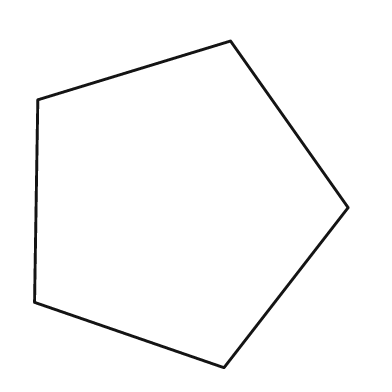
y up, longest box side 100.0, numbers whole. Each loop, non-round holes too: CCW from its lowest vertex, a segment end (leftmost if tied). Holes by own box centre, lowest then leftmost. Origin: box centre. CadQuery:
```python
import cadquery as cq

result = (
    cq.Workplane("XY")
    .moveTo(10.0, -50.0)
    .lineTo(48.0, -1.0)
    .lineTo(12.0, 50.0)
    .lineTo(-47.0, 32.0)
    .lineTo(-48.0, -30.0)
    .close()
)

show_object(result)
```